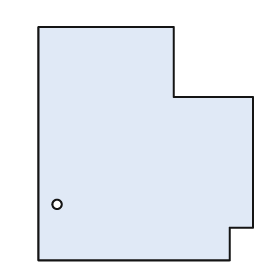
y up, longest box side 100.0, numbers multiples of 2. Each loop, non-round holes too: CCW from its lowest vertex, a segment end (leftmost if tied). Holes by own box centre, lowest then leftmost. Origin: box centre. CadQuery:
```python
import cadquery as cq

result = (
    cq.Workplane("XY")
    .moveTo(-46.0, -50.0)
    .lineTo(36.0, -50.0)
    .lineTo(36.0, -36.0)
    .lineTo(46.0, -36.0)
    .lineTo(46.0, 20.0)
    .lineTo(12.0, 20.0)
    .lineTo(12.0, 50.0)
    .lineTo(-46.0, 50.0)
    .close()
    .moveTo(-38.0, -26.0)
    .circle(2.0)
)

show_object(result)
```